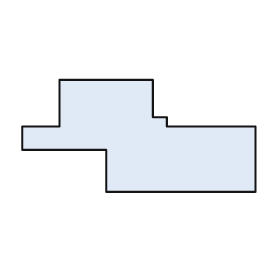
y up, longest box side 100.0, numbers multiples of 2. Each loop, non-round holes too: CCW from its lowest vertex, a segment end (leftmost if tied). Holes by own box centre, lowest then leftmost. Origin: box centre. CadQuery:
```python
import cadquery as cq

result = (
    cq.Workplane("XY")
    .moveTo(-14.0, -24.0)
    .lineTo(50.0, -24.0)
    .lineTo(50.0, 4.0)
    .lineTo(12.0, 4.0)
    .lineTo(12.0, 8.0)
    .lineTo(6.0, 8.0)
    .lineTo(6.0, 24.0)
    .lineTo(-34.0, 24.0)
    .lineTo(-34.0, 4.0)
    .lineTo(-50.0, 4.0)
    .lineTo(-50.0, -6.0)
    .lineTo(-14.0, -6.0)
    .close()
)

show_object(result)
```